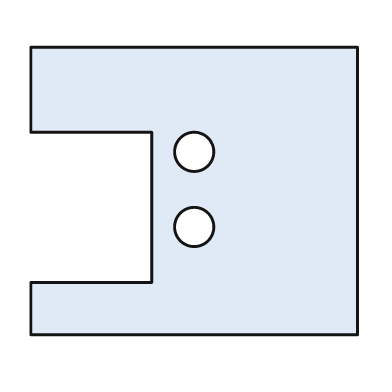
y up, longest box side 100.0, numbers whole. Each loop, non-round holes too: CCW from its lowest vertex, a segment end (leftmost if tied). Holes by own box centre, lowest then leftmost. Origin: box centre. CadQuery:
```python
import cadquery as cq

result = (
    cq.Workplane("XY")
    .moveTo(-50.0, -44.0)
    .lineTo(50.0, -44.0)
    .lineTo(50.0, 44.0)
    .lineTo(-50.0, 44.0)
    .lineTo(-50.0, 18.0)
    .lineTo(-13.0, 18.0)
    .lineTo(-13.0, -28.0)
    .lineTo(-50.0, -28.0)
    .close()
    .moveTo(0.0, -11.0)
    .circle(6.0)
    .moveTo(0.0, 12.0)
    .circle(6.0)
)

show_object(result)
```